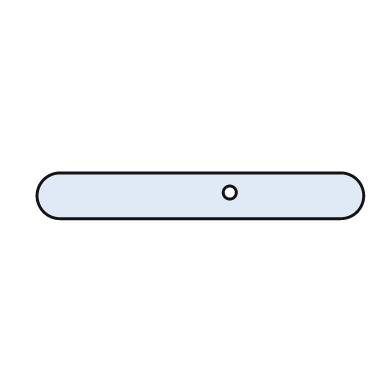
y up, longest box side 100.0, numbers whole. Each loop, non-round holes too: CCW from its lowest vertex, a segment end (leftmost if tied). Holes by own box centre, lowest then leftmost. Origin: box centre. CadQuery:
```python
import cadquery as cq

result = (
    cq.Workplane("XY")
    .moveTo(-43.0, -7.0)
    .lineTo(43.0, -7.0)
    .threePointArc((50.0, 0.0), (43.0, 7.0))
    .lineTo(-43.0, 7.0)
    .threePointArc((-50.0, 0.0), (-43.0, -7.0))
    .close()
    .moveTo(9.0, 1.0)
    .circle(2.0)
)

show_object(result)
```